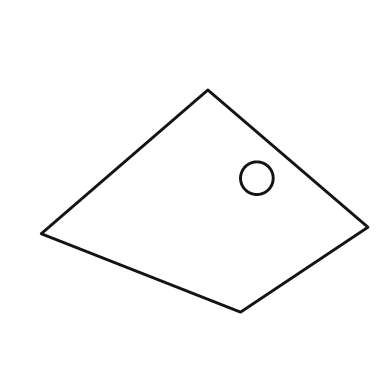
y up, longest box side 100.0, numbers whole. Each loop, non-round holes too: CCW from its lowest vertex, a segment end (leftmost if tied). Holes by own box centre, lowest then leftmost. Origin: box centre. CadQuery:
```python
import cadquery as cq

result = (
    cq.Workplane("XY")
    .moveTo(11.0, -34.0)
    .lineTo(50.0, -8.0)
    .lineTo(1.0, 34.0)
    .lineTo(-50.0, -10.0)
    .close()
    .moveTo(16.0, 7.0)
    .circle(5.0)
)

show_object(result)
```